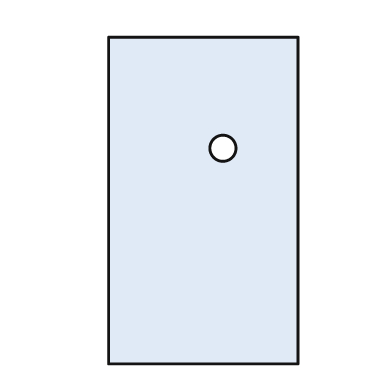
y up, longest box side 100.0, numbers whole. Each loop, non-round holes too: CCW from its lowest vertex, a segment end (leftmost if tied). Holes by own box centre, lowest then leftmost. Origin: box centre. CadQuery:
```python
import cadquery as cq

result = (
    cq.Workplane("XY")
    .moveTo(-29.0, -50.0)
    .lineTo(29.0, -50.0)
    .lineTo(29.0, 50.0)
    .lineTo(-29.0, 50.0)
    .close()
    .moveTo(6.0, 16.0)
    .circle(4.0)
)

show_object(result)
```